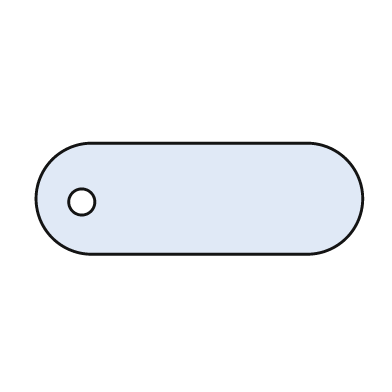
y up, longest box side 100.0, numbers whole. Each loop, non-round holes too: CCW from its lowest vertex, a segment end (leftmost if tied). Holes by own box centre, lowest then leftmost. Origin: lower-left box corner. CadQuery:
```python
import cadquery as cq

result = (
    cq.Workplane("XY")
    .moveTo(17.0, 0.0)
    .lineTo(83.0, 0.0)
    .threePointArc((100.0, 17.0), (83.0, 34.0))
    .lineTo(17.0, 34.0)
    .threePointArc((0.0, 17.0), (17.0, 0.0))
    .close()
    .moveTo(14.0, 16.0)
    .circle(4.0)
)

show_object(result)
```